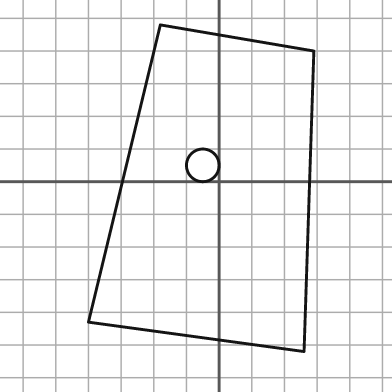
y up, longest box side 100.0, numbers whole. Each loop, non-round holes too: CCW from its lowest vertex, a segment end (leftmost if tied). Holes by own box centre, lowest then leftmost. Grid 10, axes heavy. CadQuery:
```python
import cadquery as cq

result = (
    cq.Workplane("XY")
    .moveTo(26.0, -52.0)
    .lineTo(29.0, 40.0)
    .lineTo(-18.0, 48.0)
    .lineTo(-40.0, -43.0)
    .close()
    .moveTo(-5.0, 5.0)
    .circle(5.0)
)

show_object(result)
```